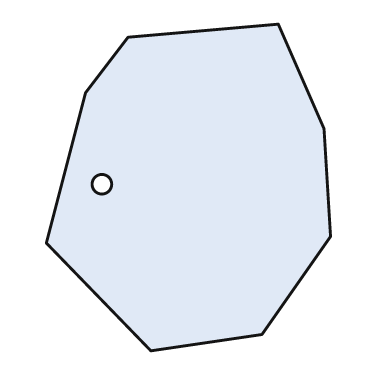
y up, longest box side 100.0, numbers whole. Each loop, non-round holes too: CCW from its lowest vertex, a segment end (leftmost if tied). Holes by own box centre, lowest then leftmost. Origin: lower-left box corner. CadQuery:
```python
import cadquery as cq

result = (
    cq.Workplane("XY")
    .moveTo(32.0, 0.0)
    .lineTo(66.0, 5.0)
    .lineTo(87.0, 35.0)
    .lineTo(85.0, 68.0)
    .lineTo(71.0, 100.0)
    .lineTo(25.0, 96.0)
    .lineTo(12.0, 79.0)
    .lineTo(0.0, 33.0)
    .close()
    .moveTo(17.0, 51.0)
    .circle(3.0)
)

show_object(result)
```